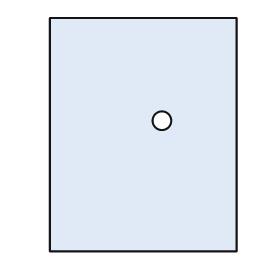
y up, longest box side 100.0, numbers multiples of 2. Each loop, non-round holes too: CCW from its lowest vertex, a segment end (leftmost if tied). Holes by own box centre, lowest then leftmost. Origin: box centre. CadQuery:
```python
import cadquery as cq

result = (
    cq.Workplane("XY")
    .moveTo(-40.0, -50.0)
    .lineTo(40.0, -50.0)
    .lineTo(40.0, 50.0)
    .lineTo(-40.0, 50.0)
    .close()
    .moveTo(8.0, 6.0)
    .circle(4.0)
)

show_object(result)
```